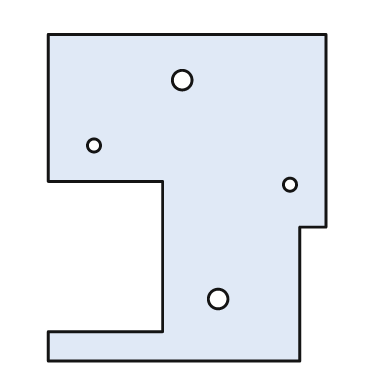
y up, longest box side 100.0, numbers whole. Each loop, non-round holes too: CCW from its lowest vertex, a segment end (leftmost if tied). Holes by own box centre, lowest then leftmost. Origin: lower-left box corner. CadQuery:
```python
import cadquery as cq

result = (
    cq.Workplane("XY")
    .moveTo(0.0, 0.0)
    .lineTo(77.0, 0.0)
    .lineTo(77.0, 41.0)
    .lineTo(85.0, 41.0)
    .lineTo(85.0, 100.0)
    .lineTo(0.0, 100.0)
    .lineTo(0.0, 55.0)
    .lineTo(35.0, 55.0)
    .lineTo(35.0, 9.0)
    .lineTo(0.0, 9.0)
    .close()
    .moveTo(52.0, 19.0)
    .circle(3.0)
    .moveTo(74.0, 54.0)
    .circle(2.0)
    .moveTo(14.0, 66.0)
    .circle(2.0)
    .moveTo(41.0, 86.0)
    .circle(3.0)
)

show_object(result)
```